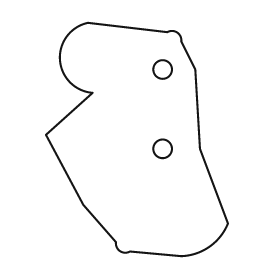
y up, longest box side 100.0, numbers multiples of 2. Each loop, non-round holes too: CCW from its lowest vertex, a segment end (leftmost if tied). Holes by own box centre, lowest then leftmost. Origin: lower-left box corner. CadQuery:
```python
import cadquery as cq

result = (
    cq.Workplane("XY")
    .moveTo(58.0, 0.0)
    .threePointArc((70.0, 4.0), (78.0, 14.0))
    .lineTo(66.0, 46.0)
    .lineTo(64.0, 80.0)
    .lineTo(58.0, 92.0)
    .threePointArc((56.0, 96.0), (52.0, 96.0))
    .lineTo(18.0, 100.0)
    .threePointArc((6.0, 84.0), (20.0, 70.0))
    .lineTo(0.0, 52.0)
    .lineTo(16.0, 22.0)
    .lineTo(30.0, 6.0)
    .threePointArc((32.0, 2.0), (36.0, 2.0))
    .close()
    .moveTo(50.0, 46.0)
    .circle(4.0)
    .moveTo(50.0, 80.0)
    .circle(4.0)
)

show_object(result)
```